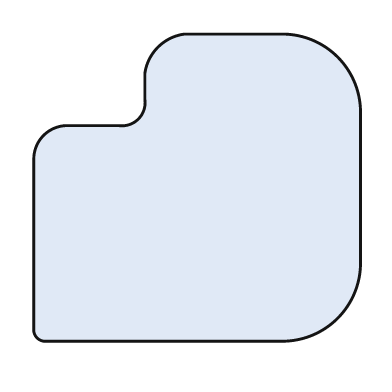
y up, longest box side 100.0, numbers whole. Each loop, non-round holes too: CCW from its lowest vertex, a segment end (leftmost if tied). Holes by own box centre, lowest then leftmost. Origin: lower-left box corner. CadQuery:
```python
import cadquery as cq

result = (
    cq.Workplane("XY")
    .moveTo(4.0, 0.0)
    .lineTo(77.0, 0.0)
    .threePointArc((93.0, 7.0), (100.0, 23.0))
    .lineTo(100.0, 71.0)
    .threePointArc((93.0, 87.0), (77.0, 94.0))
    .lineTo(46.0, 94.0)
    .threePointArc((38.0, 90.0), (34.0, 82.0))
    .lineTo(34.0, 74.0)
    .threePointArc((32.0, 68.0), (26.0, 66.0))
    .lineTo(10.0, 66.0)
    .threePointArc((3.0, 63.0), (0.0, 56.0))
    .lineTo(0.0, 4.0)
    .threePointArc((1.0, 1.0), (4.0, 0.0))
    .close()
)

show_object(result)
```